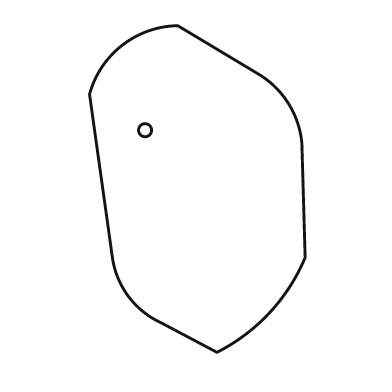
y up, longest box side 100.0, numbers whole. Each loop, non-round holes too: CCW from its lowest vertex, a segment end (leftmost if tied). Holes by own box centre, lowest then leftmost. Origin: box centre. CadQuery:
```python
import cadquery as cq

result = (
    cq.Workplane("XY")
    .moveTo(6.0, -50.0)
    .threePointArc((22.0, -38.0), (33.0, -21.0))
    .lineTo(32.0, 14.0)
    .threePointArc((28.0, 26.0), (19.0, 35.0))
    .lineTo(-6.0, 50.0)
    .threePointArc((-23.0, 44.0), (-33.0, 29.0))
    .lineTo(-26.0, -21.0)
    .threePointArc((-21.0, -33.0), (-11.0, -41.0))
    .close()
    .moveTo(-16.0, 18.0)
    .circle(2.0)
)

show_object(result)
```